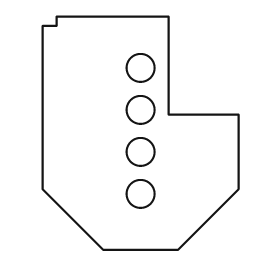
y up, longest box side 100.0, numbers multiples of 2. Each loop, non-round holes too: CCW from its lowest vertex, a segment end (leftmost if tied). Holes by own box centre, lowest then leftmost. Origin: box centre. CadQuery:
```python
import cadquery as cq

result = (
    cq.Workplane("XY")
    .moveTo(-16.0, -50.0)
    .lineTo(16.0, -50.0)
    .lineTo(42.0, -24.0)
    .lineTo(42.0, 8.0)
    .lineTo(12.0, 8.0)
    .lineTo(12.0, 50.0)
    .lineTo(-36.0, 50.0)
    .lineTo(-36.0, 46.0)
    .lineTo(-42.0, 46.0)
    .lineTo(-42.0, -24.0)
    .close()
    .moveTo(0.0, -26.0)
    .circle(6.0)
    .moveTo(0.0, -8.0)
    .circle(6.0)
    .moveTo(0.0, 10.0)
    .circle(6.0)
    .moveTo(0.0, 28.0)
    .circle(6.0)
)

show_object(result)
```